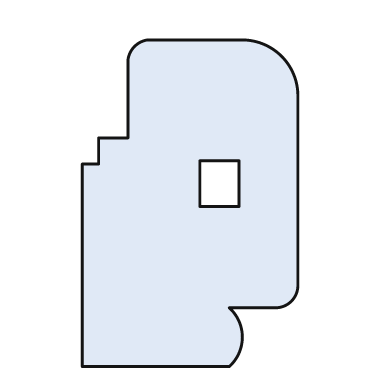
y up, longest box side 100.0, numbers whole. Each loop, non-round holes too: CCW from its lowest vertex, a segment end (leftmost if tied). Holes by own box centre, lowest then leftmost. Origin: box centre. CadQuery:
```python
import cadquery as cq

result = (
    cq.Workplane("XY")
    .moveTo(-33.0, -50.0)
    .lineTo(12.0, -50.0)
    .threePointArc((16.0, -41.0), (12.0, -32.0))
    .lineTo(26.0, -32.0)
    .threePointArc((31.0, -30.0), (33.0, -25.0))
    .lineTo(33.0, 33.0)
    .threePointArc((28.0, 45.0), (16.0, 50.0))
    .lineTo(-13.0, 50.0)
    .threePointArc((-17.0, 48.0), (-19.0, 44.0))
    .lineTo(-19.0, 20.0)
    .lineTo(-28.0, 20.0)
    .lineTo(-28.0, 12.0)
    .lineTo(-33.0, 12.0)
    .close()
    .moveTo(3.0, -1.0)
    .lineTo(15.0, -1.0)
    .lineTo(15.0, 13.0)
    .lineTo(3.0, 13.0)
    .close()
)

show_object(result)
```